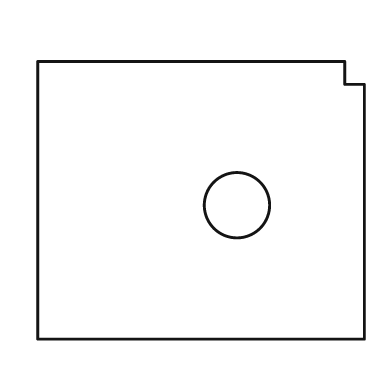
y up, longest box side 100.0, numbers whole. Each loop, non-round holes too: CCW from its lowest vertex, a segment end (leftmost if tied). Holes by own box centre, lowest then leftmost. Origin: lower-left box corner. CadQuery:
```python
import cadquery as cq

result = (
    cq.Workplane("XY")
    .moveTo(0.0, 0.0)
    .lineTo(100.0, 0.0)
    .lineTo(100.0, 78.0)
    .lineTo(94.0, 78.0)
    .lineTo(94.0, 85.0)
    .lineTo(0.0, 85.0)
    .close()
    .moveTo(61.0, 41.0)
    .circle(10.0)
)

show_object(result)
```